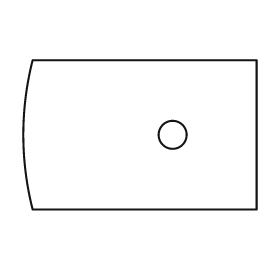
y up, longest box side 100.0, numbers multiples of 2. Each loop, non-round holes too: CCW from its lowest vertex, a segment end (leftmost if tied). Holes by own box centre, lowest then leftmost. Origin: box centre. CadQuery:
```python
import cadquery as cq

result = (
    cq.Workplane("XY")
    .moveTo(-46.0, -32.0)
    .lineTo(50.0, -32.0)
    .lineTo(50.0, 32.0)
    .lineTo(-46.0, 32.0)
    .threePointArc((-50.0, 0.0), (-46.0, -32.0))
    .close()
    .moveTo(14.0, 0.0)
    .circle(6.0)
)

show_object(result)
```